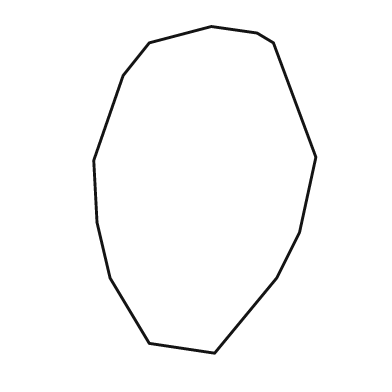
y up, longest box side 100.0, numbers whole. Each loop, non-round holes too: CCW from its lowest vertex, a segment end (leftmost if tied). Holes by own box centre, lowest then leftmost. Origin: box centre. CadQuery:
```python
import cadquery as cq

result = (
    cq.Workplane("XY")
    .moveTo(3.0, -50.0)
    .lineTo(22.0, -27.0)
    .lineTo(29.0, -13.0)
    .lineTo(34.0, 10.0)
    .lineTo(21.0, 45.0)
    .lineTo(16.0, 48.0)
    .lineTo(2.0, 50.0)
    .lineTo(-17.0, 45.0)
    .lineTo(-25.0, 35.0)
    .lineTo(-34.0, 9.0)
    .lineTo(-33.0, -10.0)
    .lineTo(-29.0, -27.0)
    .lineTo(-17.0, -47.0)
    .close()
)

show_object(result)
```